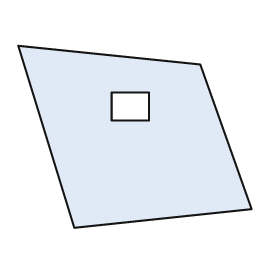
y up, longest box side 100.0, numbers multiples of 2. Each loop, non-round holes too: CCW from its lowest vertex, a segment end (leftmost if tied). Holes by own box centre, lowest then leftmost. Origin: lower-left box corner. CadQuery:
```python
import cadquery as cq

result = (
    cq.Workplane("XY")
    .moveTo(24.0, 0.0)
    .lineTo(100.0, 8.0)
    .lineTo(78.0, 70.0)
    .lineTo(0.0, 78.0)
    .close()
    .moveTo(40.0, 46.0)
    .lineTo(56.0, 46.0)
    .lineTo(56.0, 58.0)
    .lineTo(40.0, 58.0)
    .close()
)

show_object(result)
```